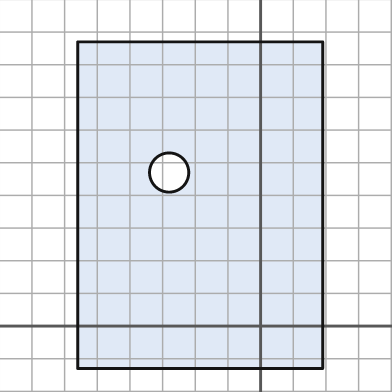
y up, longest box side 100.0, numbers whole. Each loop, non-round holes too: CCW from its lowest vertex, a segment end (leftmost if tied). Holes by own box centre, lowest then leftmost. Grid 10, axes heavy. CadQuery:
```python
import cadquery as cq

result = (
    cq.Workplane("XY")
    .moveTo(-56.0, -13.0)
    .lineTo(19.0, -13.0)
    .lineTo(19.0, 87.0)
    .lineTo(-56.0, 87.0)
    .close()
    .moveTo(-28.0, 47.0)
    .circle(6.0)
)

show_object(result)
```